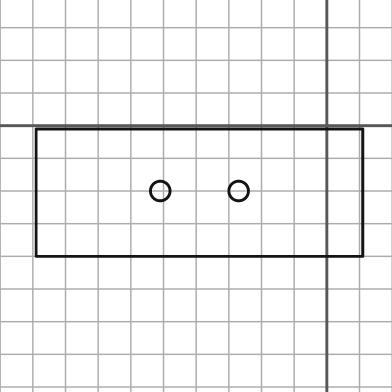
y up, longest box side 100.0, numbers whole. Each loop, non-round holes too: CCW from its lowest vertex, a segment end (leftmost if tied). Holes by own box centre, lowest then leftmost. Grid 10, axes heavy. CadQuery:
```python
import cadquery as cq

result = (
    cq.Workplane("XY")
    .moveTo(-89.0, -40.0)
    .lineTo(11.0, -40.0)
    .lineTo(11.0, -1.0)
    .lineTo(-89.0, -1.0)
    .close()
    .moveTo(-51.0, -20.0)
    .circle(3.0)
    .moveTo(-27.0, -20.0)
    .circle(3.0)
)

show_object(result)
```